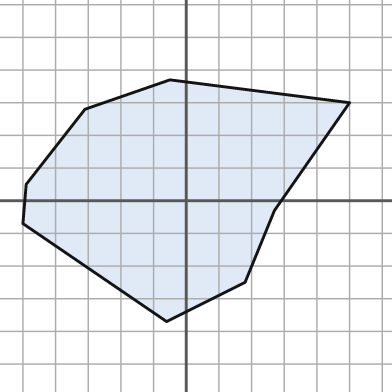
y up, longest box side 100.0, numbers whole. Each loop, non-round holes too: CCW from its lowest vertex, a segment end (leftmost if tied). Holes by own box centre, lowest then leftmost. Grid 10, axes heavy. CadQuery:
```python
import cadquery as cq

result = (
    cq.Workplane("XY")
    .moveTo(-6.0, -37.0)
    .lineTo(18.0, -25.0)
    .lineTo(27.0, -3.0)
    .lineTo(50.0, 30.0)
    .lineTo(-5.0, 37.0)
    .lineTo(-31.0, 28.0)
    .lineTo(-49.0, 5.0)
    .lineTo(-50.0, -7.0)
    .close()
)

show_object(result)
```